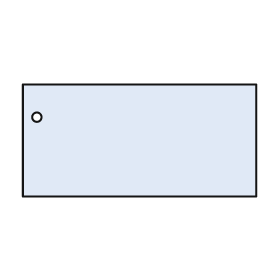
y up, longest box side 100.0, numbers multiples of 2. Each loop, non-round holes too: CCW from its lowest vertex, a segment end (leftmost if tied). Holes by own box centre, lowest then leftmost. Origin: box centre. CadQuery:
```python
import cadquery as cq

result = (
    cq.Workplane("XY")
    .moveTo(-50.0, -24.0)
    .lineTo(50.0, -24.0)
    .lineTo(50.0, 24.0)
    .lineTo(-50.0, 24.0)
    .close()
    .moveTo(-44.0, 10.0)
    .circle(2.0)
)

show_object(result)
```